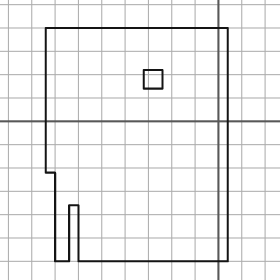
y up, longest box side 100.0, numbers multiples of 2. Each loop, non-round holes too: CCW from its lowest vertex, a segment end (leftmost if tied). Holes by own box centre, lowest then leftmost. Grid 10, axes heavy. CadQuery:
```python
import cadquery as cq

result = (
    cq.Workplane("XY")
    .moveTo(-70.0, -60.0)
    .lineTo(-64.0, -60.0)
    .lineTo(-64.0, -36.0)
    .lineTo(-60.0, -36.0)
    .lineTo(-60.0, -60.0)
    .lineTo(4.0, -60.0)
    .lineTo(4.0, 40.0)
    .lineTo(-74.0, 40.0)
    .lineTo(-74.0, -22.0)
    .lineTo(-70.0, -22.0)
    .close()
    .moveTo(-32.0, 14.0)
    .lineTo(-24.0, 14.0)
    .lineTo(-24.0, 22.0)
    .lineTo(-32.0, 22.0)
    .close()
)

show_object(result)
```